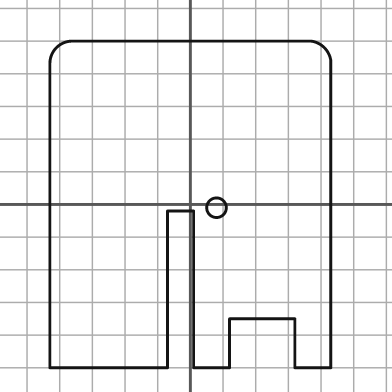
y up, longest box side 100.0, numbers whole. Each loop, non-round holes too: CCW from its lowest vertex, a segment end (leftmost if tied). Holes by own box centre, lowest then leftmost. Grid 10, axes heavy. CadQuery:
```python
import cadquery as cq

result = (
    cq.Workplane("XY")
    .moveTo(-43.0, -50.0)
    .lineTo(-7.0, -50.0)
    .lineTo(-7.0, -2.0)
    .lineTo(1.0, -2.0)
    .lineTo(1.0, -50.0)
    .lineTo(12.0, -50.0)
    .lineTo(12.0, -35.0)
    .lineTo(32.0, -35.0)
    .lineTo(32.0, -50.0)
    .lineTo(43.0, -50.0)
    .lineTo(43.0, 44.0)
    .threePointArc((41.0, 48.0), (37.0, 50.0))
    .lineTo(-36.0, 50.0)
    .threePointArc((-41.0, 48.0), (-43.0, 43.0))
    .close()
    .moveTo(8.0, -1.0)
    .circle(3.0)
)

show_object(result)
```